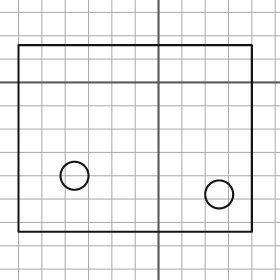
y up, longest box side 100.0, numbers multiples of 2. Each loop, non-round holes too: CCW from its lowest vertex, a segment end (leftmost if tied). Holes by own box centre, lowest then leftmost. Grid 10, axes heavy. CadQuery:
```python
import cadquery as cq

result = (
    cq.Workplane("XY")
    .moveTo(-60.0, -64.0)
    .lineTo(40.0, -64.0)
    .lineTo(40.0, 16.0)
    .lineTo(-60.0, 16.0)
    .close()
    .moveTo(26.0, -48.0)
    .circle(6.0)
    .moveTo(-36.0, -40.0)
    .circle(6.0)
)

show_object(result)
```